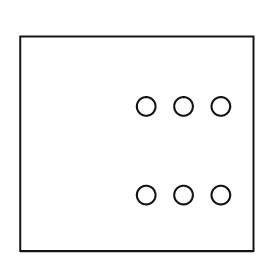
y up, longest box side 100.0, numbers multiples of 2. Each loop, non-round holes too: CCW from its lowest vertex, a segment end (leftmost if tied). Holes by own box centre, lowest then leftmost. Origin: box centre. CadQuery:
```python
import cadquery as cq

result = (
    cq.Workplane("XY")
    .moveTo(-50.0, -46.0)
    .lineTo(50.0, -46.0)
    .lineTo(50.0, 46.0)
    .lineTo(-50.0, 46.0)
    .close()
    .moveTo(4.0, -22.0)
    .circle(4.0)
    .moveTo(20.0, -22.0)
    .circle(4.0)
    .moveTo(36.0, -22.0)
    .circle(4.0)
    .moveTo(4.0, 16.0)
    .circle(4.0)
    .moveTo(20.0, 16.0)
    .circle(4.0)
    .moveTo(36.0, 16.0)
    .circle(4.0)
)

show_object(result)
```